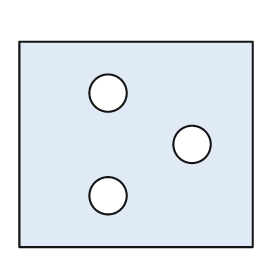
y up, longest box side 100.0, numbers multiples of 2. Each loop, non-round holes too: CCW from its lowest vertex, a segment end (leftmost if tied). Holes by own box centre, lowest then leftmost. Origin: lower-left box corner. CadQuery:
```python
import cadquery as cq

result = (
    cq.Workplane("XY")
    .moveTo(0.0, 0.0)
    .lineTo(100.0, 0.0)
    .lineTo(100.0, 88.0)
    .lineTo(0.0, 88.0)
    .close()
    .moveTo(38.0, 22.0)
    .circle(8.0)
    .moveTo(74.0, 44.0)
    .circle(8.0)
    .moveTo(38.0, 66.0)
    .circle(8.0)
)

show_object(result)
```